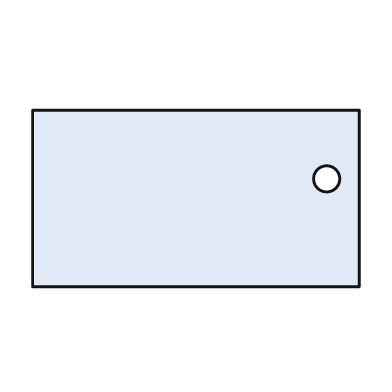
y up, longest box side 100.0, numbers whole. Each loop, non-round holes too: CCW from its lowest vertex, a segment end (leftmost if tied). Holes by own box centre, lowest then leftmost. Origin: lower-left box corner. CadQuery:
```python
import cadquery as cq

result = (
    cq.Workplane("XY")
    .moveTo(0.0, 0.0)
    .lineTo(100.0, 0.0)
    .lineTo(100.0, 54.0)
    .lineTo(0.0, 54.0)
    .close()
    .moveTo(90.0, 33.0)
    .circle(4.0)
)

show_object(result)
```